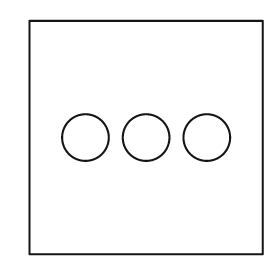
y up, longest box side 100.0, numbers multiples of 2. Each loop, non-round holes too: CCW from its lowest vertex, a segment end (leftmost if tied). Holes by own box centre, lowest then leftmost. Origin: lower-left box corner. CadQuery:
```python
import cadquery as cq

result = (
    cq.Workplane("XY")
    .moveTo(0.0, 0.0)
    .lineTo(100.0, 0.0)
    .lineTo(100.0, 100.0)
    .lineTo(0.0, 100.0)
    .close()
    .moveTo(24.0, 50.0)
    .circle(10.0)
    .moveTo(50.0, 50.0)
    .circle(10.0)
    .moveTo(76.0, 50.0)
    .circle(10.0)
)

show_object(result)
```